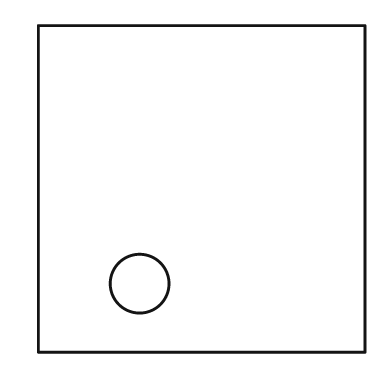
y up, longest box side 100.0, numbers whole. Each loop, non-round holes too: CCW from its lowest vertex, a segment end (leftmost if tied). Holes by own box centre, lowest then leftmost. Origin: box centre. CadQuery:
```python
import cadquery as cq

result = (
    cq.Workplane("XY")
    .moveTo(-50.0, -50.0)
    .lineTo(50.0, -50.0)
    .lineTo(50.0, 50.0)
    .lineTo(-50.0, 50.0)
    .close()
    .moveTo(-19.0, -29.0)
    .circle(9.0)
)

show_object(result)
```